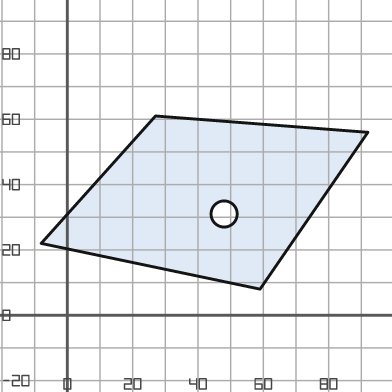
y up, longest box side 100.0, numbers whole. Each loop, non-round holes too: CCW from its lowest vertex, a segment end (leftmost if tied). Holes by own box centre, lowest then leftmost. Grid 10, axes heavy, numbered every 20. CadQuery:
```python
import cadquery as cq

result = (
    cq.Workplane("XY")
    .moveTo(59.0, 8.0)
    .lineTo(92.0, 56.0)
    .lineTo(27.0, 61.0)
    .lineTo(-8.0, 22.0)
    .close()
    .moveTo(48.0, 31.0)
    .circle(4.0)
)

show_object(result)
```